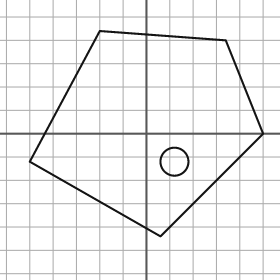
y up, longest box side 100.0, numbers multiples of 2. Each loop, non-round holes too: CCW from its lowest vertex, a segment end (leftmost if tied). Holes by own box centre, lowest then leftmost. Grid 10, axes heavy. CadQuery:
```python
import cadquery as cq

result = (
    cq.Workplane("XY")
    .moveTo(6.0, -44.0)
    .lineTo(50.0, 0.0)
    .lineTo(34.0, 40.0)
    .lineTo(-20.0, 44.0)
    .lineTo(-50.0, -12.0)
    .close()
    .moveTo(12.0, -12.0)
    .circle(6.0)
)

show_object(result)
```